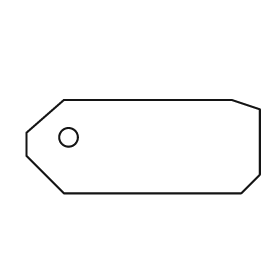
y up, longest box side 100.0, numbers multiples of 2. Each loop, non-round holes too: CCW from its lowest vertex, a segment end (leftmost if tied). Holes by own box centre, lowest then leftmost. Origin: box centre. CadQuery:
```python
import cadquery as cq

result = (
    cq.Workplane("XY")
    .moveTo(-34.0, -20.0)
    .lineTo(42.0, -20.0)
    .lineTo(50.0, -12.0)
    .lineTo(50.0, 16.0)
    .lineTo(38.0, 20.0)
    .lineTo(-34.0, 20.0)
    .lineTo(-50.0, 6.0)
    .lineTo(-50.0, -4.0)
    .close()
    .moveTo(-32.0, 4.0)
    .circle(4.0)
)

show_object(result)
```